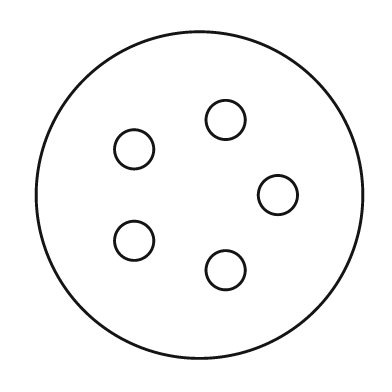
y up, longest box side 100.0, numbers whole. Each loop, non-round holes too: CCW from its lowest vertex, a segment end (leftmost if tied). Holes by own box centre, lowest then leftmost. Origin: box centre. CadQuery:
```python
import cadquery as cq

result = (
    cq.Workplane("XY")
    .moveTo(0.0, 0.0)
    .circle(50.0)
    .moveTo(8.0, -23.0)
    .circle(6.0)
    .moveTo(-20.0, -14.0)
    .circle(6.0)
    .moveTo(24.0, 0.0)
    .circle(6.0)
    .moveTo(-20.0, 14.0)
    .circle(6.0)
    .moveTo(8.0, 23.0)
    .circle(6.0)
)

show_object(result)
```